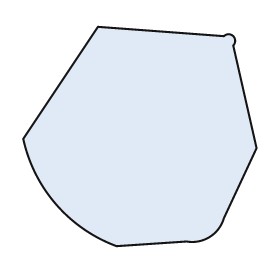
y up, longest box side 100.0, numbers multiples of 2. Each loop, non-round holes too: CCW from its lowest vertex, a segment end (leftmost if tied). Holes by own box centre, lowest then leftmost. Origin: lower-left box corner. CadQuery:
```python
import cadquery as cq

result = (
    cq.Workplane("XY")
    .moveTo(40.0, 0.0)
    .lineTo(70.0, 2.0)
    .threePointArc((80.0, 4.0), (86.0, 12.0))
    .lineTo(100.0, 42.0)
    .lineTo(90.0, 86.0)
    .threePointArc((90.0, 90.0), (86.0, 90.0))
    .lineTo(32.0, 94.0)
    .lineTo(0.0, 46.0)
    .threePointArc((14.0, 18.0), (40.0, 0.0))
    .close()
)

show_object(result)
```